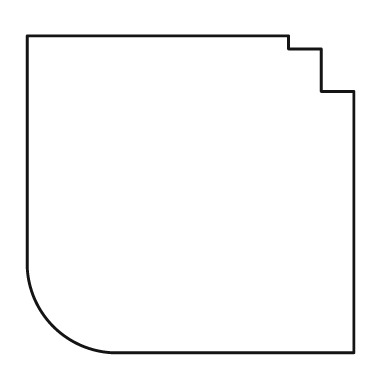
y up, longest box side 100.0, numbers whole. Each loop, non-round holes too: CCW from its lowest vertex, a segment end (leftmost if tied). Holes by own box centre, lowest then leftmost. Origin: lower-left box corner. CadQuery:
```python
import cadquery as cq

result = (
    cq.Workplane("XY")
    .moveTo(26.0, 0.0)
    .lineTo(100.0, 0.0)
    .lineTo(100.0, 80.0)
    .lineTo(90.0, 80.0)
    .lineTo(90.0, 93.0)
    .lineTo(80.0, 93.0)
    .lineTo(80.0, 97.0)
    .lineTo(0.0, 97.0)
    .lineTo(0.0, 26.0)
    .threePointArc((8.0, 8.0), (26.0, 0.0))
    .close()
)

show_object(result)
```